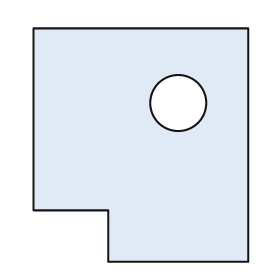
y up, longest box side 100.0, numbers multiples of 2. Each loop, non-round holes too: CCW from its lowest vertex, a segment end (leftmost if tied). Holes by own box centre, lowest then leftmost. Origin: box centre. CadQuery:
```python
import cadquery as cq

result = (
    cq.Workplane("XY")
    .moveTo(-14.0, -50.0)
    .lineTo(46.0, -50.0)
    .lineTo(46.0, 50.0)
    .lineTo(-46.0, 50.0)
    .lineTo(-46.0, -28.0)
    .lineTo(-14.0, -28.0)
    .close()
    .moveTo(16.0, 18.0)
    .circle(12.0)
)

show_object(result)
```